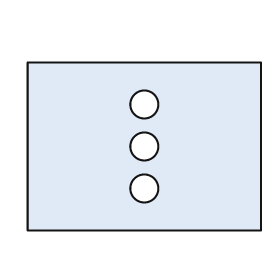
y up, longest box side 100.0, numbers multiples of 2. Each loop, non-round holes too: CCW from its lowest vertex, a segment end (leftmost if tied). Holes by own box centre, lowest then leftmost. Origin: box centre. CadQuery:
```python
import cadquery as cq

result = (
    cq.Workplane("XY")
    .moveTo(-50.0, -36.0)
    .lineTo(50.0, -36.0)
    .lineTo(50.0, 36.0)
    .lineTo(-50.0, 36.0)
    .close()
    .moveTo(0.0, -18.0)
    .circle(6.0)
    .moveTo(0.0, 0.0)
    .circle(6.0)
    .moveTo(0.0, 18.0)
    .circle(6.0)
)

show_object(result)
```